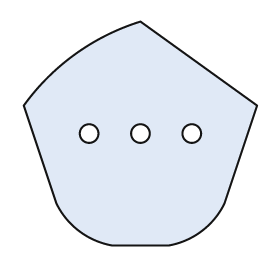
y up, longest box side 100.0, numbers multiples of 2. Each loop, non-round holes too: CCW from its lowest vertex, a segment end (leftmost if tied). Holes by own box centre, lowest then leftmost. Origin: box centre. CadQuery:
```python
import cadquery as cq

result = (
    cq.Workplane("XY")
    .moveTo(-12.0, -48.0)
    .lineTo(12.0, -48.0)
    .threePointArc((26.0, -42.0), (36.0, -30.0))
    .lineTo(50.0, 12.0)
    .lineTo(0.0, 48.0)
    .threePointArc((-28.0, 34.0), (-50.0, 12.0))
    .lineTo(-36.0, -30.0)
    .threePointArc((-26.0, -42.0), (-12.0, -48.0))
    .close()
    .moveTo(-22.0, 0.0)
    .circle(4.0)
    .moveTo(0.0, 0.0)
    .circle(4.0)
    .moveTo(22.0, 0.0)
    .circle(4.0)
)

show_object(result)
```